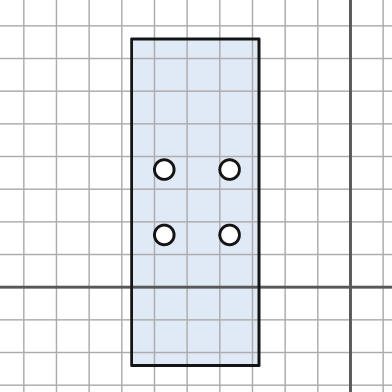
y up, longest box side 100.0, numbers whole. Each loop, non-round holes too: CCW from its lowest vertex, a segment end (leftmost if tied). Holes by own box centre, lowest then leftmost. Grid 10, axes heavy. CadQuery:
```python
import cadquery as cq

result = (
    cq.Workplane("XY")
    .moveTo(-67.0, -24.0)
    .lineTo(-28.0, -24.0)
    .lineTo(-28.0, 76.0)
    .lineTo(-67.0, 76.0)
    .close()
    .moveTo(-57.0, 16.0)
    .circle(3.0)
    .moveTo(-37.0, 16.0)
    .circle(3.0)
    .moveTo(-57.0, 36.0)
    .circle(3.0)
    .moveTo(-37.0, 36.0)
    .circle(3.0)
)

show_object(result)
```